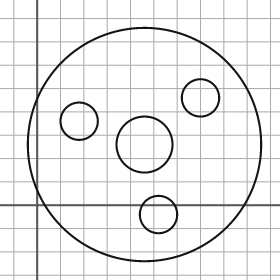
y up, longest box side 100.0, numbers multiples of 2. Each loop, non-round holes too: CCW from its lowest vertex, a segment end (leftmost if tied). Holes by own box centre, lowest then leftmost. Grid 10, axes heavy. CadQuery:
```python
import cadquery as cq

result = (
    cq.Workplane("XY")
    .moveTo(46.0, 26.0)
    .circle(50.0)
    .moveTo(52.0, -4.0)
    .circle(8.0)
    .moveTo(46.0, 26.0)
    .circle(12.0)
    .moveTo(18.0, 36.0)
    .circle(8.0)
    .moveTo(70.0, 46.0)
    .circle(8.0)
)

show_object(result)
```